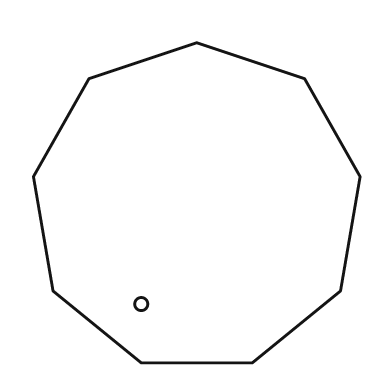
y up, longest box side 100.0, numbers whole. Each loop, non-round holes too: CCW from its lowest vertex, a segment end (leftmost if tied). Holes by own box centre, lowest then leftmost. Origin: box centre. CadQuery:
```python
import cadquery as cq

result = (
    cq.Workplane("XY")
    .moveTo(-17.0, -49.0)
    .lineTo(17.0, -49.0)
    .lineTo(44.0, -27.0)
    .lineTo(50.0, 8.0)
    .lineTo(33.0, 38.0)
    .lineTo(0.0, 49.0)
    .lineTo(-33.0, 38.0)
    .lineTo(-50.0, 8.0)
    .lineTo(-44.0, -27.0)
    .close()
    .moveTo(-17.0, -31.0)
    .circle(2.0)
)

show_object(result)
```